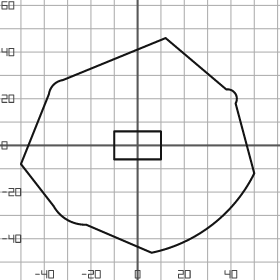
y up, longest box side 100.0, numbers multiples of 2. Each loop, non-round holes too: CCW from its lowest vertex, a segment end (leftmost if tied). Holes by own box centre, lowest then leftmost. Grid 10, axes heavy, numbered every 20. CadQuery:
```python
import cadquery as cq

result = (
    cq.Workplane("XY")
    .moveTo(6.0, -46.0)
    .threePointArc((32.0, -34.0), (50.0, -12.0))
    .lineTo(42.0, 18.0)
    .threePointArc((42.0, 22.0), (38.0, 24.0))
    .lineTo(12.0, 46.0)
    .lineTo(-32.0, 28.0)
    .threePointArc((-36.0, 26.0), (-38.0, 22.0))
    .lineTo(-50.0, -8.0)
    .lineTo(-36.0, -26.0)
    .threePointArc((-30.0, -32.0), (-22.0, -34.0))
    .close()
    .moveTo(-10.0, -6.0)
    .lineTo(10.0, -6.0)
    .lineTo(10.0, 6.0)
    .lineTo(-10.0, 6.0)
    .close()
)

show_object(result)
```